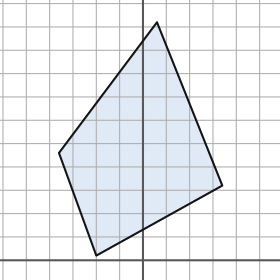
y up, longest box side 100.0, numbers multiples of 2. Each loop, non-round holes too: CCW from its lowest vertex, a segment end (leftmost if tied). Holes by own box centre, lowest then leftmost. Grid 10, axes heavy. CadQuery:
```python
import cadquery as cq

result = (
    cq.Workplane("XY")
    .moveTo(-20.0, 2.0)
    .lineTo(34.0, 32.0)
    .lineTo(6.0, 102.0)
    .lineTo(-36.0, 46.0)
    .close()
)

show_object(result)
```